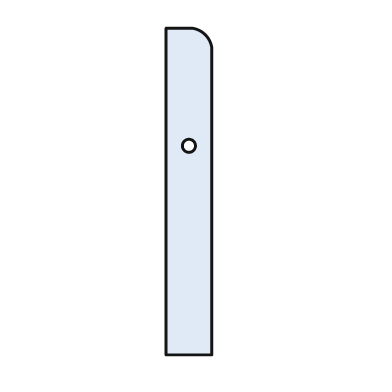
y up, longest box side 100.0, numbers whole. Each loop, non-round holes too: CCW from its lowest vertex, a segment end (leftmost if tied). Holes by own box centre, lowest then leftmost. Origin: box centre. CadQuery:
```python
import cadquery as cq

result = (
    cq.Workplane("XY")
    .moveTo(-7.0, -50.0)
    .lineTo(7.0, -50.0)
    .lineTo(7.0, 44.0)
    .threePointArc((5.0, 48.0), (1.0, 50.0))
    .lineTo(-7.0, 50.0)
    .close()
    .moveTo(0.0, 14.0)
    .circle(2.0)
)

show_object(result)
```